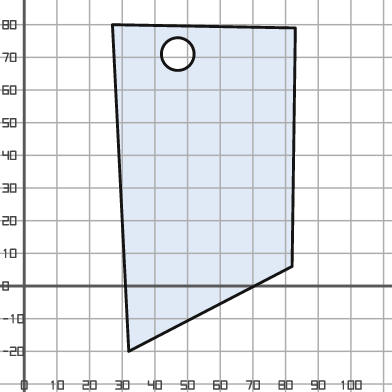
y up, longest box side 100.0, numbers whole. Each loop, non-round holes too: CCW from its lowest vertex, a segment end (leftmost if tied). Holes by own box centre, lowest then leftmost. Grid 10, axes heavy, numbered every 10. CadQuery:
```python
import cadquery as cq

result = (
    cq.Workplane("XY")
    .moveTo(32.0, -20.0)
    .lineTo(82.0, 6.0)
    .lineTo(83.0, 79.0)
    .lineTo(27.0, 80.0)
    .close()
    .moveTo(47.0, 71.0)
    .circle(5.0)
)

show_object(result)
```